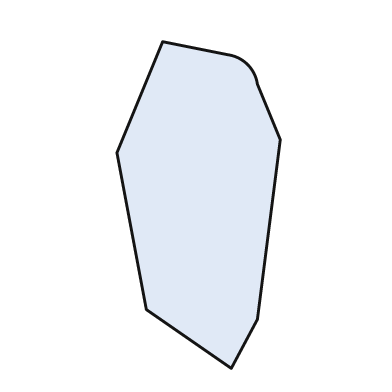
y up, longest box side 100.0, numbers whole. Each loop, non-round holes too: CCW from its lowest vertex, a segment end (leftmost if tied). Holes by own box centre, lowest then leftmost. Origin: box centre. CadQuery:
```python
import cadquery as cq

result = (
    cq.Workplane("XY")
    .moveTo(10.0, -50.0)
    .lineTo(18.0, -35.0)
    .lineTo(25.0, 20.0)
    .lineTo(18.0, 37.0)
    .threePointArc((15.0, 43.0), (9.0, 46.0))
    .lineTo(-11.0, 50.0)
    .lineTo(-25.0, 16.0)
    .lineTo(-16.0, -32.0)
    .close()
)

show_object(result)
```